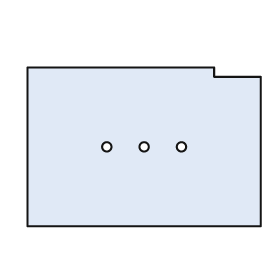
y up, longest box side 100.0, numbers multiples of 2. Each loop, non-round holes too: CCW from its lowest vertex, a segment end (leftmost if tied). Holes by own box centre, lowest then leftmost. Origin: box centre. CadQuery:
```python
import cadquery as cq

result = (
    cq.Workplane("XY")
    .moveTo(-50.0, -34.0)
    .lineTo(50.0, -34.0)
    .lineTo(50.0, 30.0)
    .lineTo(30.0, 30.0)
    .lineTo(30.0, 34.0)
    .lineTo(-50.0, 34.0)
    .close()
    .moveTo(-16.0, 0.0)
    .circle(2.0)
    .moveTo(0.0, 0.0)
    .circle(2.0)
    .moveTo(16.0, 0.0)
    .circle(2.0)
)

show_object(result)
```